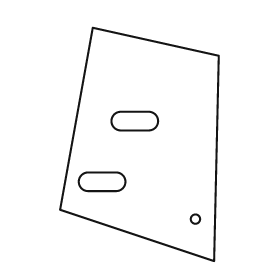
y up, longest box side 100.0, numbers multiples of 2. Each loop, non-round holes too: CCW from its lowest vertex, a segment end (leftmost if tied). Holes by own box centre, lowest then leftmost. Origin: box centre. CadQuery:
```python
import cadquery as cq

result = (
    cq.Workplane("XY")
    .moveTo(32.0, -50.0)
    .lineTo(34.0, 38.0)
    .lineTo(-20.0, 50.0)
    .lineTo(-34.0, -28.0)
    .close()
    .moveTo(24.0, -32.0)
    .circle(2.0)
    .moveTo(-22.0, -20.0)
    .lineTo(-10.0, -20.0)
    .threePointArc((-6.0, -16.0), (-10.0, -12.0))
    .lineTo(-22.0, -12.0)
    .threePointArc((-26.0, -16.0), (-22.0, -20.0))
    .close()
    .moveTo(-8.0, 6.0)
    .lineTo(4.0, 6.0)
    .threePointArc((8.0, 10.0), (4.0, 14.0))
    .lineTo(-8.0, 14.0)
    .threePointArc((-12.0, 10.0), (-8.0, 6.0))
    .close()
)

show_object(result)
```